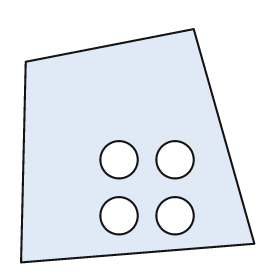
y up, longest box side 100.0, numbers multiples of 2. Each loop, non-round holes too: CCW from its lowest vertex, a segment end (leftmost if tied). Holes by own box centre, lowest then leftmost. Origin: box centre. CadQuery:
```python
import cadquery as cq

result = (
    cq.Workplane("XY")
    .moveTo(-50.0, -50.0)
    .lineTo(50.0, -42.0)
    .lineTo(24.0, 50.0)
    .lineTo(-48.0, 36.0)
    .close()
    .moveTo(-8.0, -30.0)
    .circle(8.0)
    .moveTo(16.0, -30.0)
    .circle(8.0)
    .moveTo(-8.0, -6.0)
    .circle(8.0)
    .moveTo(16.0, -6.0)
    .circle(8.0)
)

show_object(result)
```